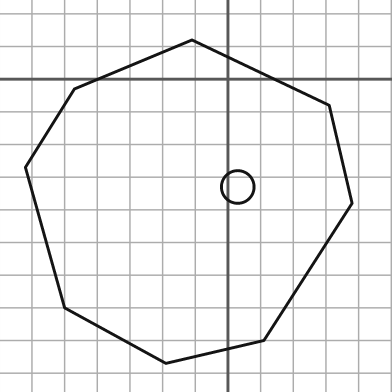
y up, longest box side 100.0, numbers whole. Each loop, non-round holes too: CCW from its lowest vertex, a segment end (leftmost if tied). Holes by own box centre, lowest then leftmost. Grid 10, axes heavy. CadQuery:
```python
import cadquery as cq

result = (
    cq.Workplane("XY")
    .moveTo(-19.0, -87.0)
    .lineTo(11.0, -80.0)
    .lineTo(38.0, -38.0)
    .lineTo(31.0, -8.0)
    .lineTo(-11.0, 12.0)
    .lineTo(-47.0, -3.0)
    .lineTo(-62.0, -27.0)
    .lineTo(-50.0, -70.0)
    .close()
    .moveTo(3.0, -33.0)
    .circle(5.0)
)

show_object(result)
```